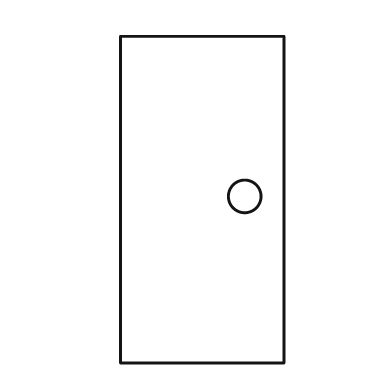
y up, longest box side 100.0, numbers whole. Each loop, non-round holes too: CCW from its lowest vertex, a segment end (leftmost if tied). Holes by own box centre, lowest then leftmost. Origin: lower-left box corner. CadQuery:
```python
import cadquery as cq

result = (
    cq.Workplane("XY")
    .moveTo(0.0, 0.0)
    .lineTo(50.0, 0.0)
    .lineTo(50.0, 100.0)
    .lineTo(0.0, 100.0)
    .close()
    .moveTo(38.0, 51.0)
    .circle(5.0)
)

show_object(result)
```